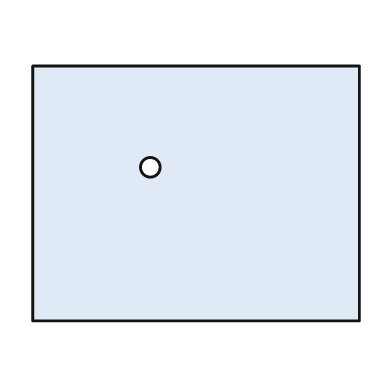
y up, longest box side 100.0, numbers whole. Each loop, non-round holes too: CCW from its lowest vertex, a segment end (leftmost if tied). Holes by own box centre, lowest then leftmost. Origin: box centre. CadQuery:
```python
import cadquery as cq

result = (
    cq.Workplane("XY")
    .moveTo(-50.0, -39.0)
    .lineTo(50.0, -39.0)
    .lineTo(50.0, 39.0)
    .lineTo(-50.0, 39.0)
    .close()
    .moveTo(-14.0, 8.0)
    .circle(3.0)
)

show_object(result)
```